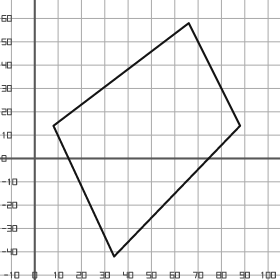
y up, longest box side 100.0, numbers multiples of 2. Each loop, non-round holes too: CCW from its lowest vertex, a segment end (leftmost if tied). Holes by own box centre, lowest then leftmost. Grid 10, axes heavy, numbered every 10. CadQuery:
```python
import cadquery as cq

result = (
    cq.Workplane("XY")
    .moveTo(34.0, -42.0)
    .lineTo(88.0, 14.0)
    .lineTo(66.0, 58.0)
    .lineTo(8.0, 14.0)
    .close()
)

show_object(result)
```